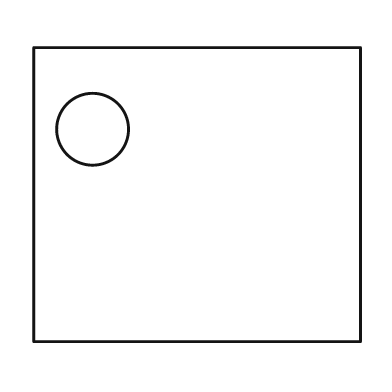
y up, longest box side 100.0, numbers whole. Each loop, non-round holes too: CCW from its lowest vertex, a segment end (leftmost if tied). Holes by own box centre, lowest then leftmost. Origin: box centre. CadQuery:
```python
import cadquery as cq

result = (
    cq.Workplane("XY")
    .moveTo(-50.0, -45.0)
    .lineTo(50.0, -45.0)
    .lineTo(50.0, 45.0)
    .lineTo(-50.0, 45.0)
    .close()
    .moveTo(-32.0, 20.0)
    .circle(11.0)
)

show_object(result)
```